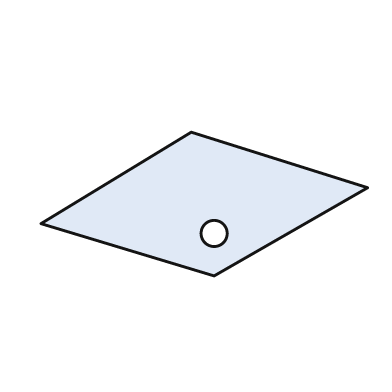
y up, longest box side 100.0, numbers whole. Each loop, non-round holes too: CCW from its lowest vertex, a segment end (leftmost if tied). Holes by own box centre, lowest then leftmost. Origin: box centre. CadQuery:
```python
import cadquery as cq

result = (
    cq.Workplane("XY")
    .moveTo(3.0, -22.0)
    .lineTo(50.0, 5.0)
    .lineTo(-4.0, 22.0)
    .lineTo(-50.0, -6.0)
    .close()
    .moveTo(3.0, -9.0)
    .circle(4.0)
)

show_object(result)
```